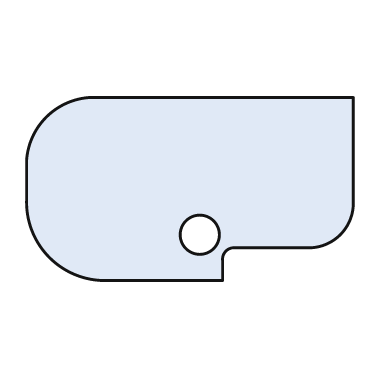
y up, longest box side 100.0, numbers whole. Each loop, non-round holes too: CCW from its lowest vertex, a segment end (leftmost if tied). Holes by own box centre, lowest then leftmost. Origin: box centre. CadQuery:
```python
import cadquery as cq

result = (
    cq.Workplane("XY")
    .moveTo(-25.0, -28.0)
    .lineTo(10.0, -28.0)
    .lineTo(10.0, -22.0)
    .threePointArc((11.0, -19.0), (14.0, -18.0))
    .lineTo(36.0, -18.0)
    .threePointArc((46.0, -14.0), (50.0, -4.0))
    .lineTo(50.0, 28.0)
    .lineTo(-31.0, 28.0)
    .threePointArc((-44.0, 22.0), (-50.0, 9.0))
    .lineTo(-50.0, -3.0)
    .threePointArc((-43.0, -21.0), (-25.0, -28.0))
    .close()
    .moveTo(3.0, -14.0)
    .circle(6.0)
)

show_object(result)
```